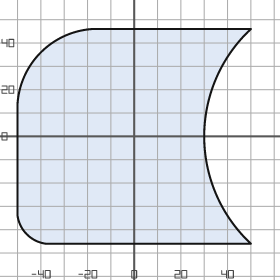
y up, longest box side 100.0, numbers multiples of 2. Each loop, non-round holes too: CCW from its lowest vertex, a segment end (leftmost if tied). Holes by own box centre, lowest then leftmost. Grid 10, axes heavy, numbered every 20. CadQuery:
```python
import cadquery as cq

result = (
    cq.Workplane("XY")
    .moveTo(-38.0, -46.0)
    .lineTo(50.0, -46.0)
    .threePointArc((30.0, 0.0), (50.0, 46.0))
    .lineTo(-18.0, 46.0)
    .threePointArc((-40.0, 36.0), (-50.0, 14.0))
    .lineTo(-50.0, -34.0)
    .threePointArc((-46.0, -42.0), (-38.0, -46.0))
    .close()
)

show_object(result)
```